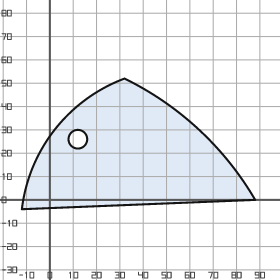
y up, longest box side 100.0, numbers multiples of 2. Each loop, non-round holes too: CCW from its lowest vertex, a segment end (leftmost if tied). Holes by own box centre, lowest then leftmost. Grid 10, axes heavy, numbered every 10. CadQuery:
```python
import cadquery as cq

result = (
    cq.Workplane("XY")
    .moveTo(-12.0, -4.0)
    .lineTo(88.0, 0.0)
    .threePointArc((64.0, 30.0), (32.0, 52.0))
    .threePointArc((2.0, 30.0), (-12.0, -4.0))
    .close()
    .moveTo(12.0, 26.0)
    .circle(4.0)
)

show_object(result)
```